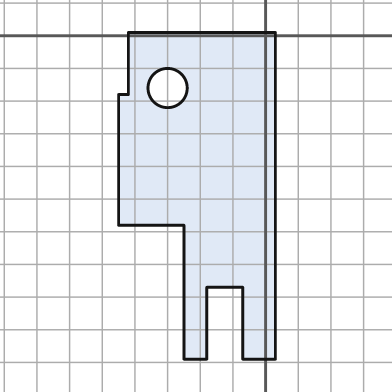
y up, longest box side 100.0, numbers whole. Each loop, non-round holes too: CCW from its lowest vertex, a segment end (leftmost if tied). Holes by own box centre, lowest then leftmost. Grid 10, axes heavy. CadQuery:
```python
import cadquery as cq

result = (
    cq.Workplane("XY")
    .moveTo(-25.0, -99.0)
    .lineTo(-18.0, -99.0)
    .lineTo(-18.0, -77.0)
    .lineTo(-7.0, -77.0)
    .lineTo(-7.0, -99.0)
    .lineTo(3.0, -99.0)
    .lineTo(3.0, 1.0)
    .lineTo(-42.0, 1.0)
    .lineTo(-42.0, -18.0)
    .lineTo(-45.0, -18.0)
    .lineTo(-45.0, -58.0)
    .lineTo(-25.0, -58.0)
    .close()
    .moveTo(-30.0, -16.0)
    .circle(6.0)
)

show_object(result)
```